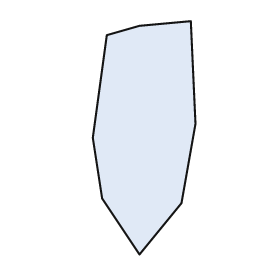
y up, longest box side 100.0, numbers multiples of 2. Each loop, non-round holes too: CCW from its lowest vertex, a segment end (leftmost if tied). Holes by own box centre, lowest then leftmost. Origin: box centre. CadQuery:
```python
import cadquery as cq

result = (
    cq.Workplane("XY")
    .moveTo(-2.0, -50.0)
    .lineTo(16.0, -28.0)
    .lineTo(22.0, 6.0)
    .lineTo(20.0, 50.0)
    .lineTo(-2.0, 48.0)
    .lineTo(-16.0, 44.0)
    .lineTo(-22.0, 0.0)
    .lineTo(-18.0, -26.0)
    .close()
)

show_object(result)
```